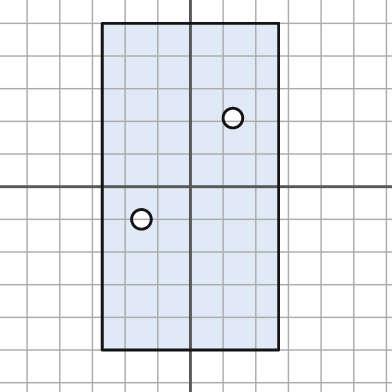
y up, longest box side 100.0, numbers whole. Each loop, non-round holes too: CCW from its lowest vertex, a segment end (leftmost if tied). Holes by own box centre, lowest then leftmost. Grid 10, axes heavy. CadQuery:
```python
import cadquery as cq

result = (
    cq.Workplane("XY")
    .moveTo(-27.0, -50.0)
    .lineTo(27.0, -50.0)
    .lineTo(27.0, 50.0)
    .lineTo(-27.0, 50.0)
    .close()
    .moveTo(-15.0, -10.0)
    .circle(3.0)
    .moveTo(13.0, 21.0)
    .circle(3.0)
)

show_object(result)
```